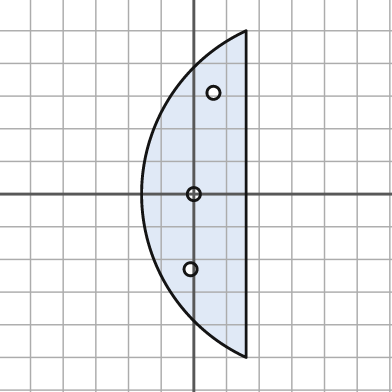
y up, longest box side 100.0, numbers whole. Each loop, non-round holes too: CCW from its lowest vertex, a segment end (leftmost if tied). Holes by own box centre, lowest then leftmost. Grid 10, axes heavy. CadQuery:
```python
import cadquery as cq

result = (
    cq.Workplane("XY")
    .moveTo(16.0, -50.0)
    .lineTo(16.0, 50.0)
    .threePointArc((-16.0, 0.0), (16.0, -50.0))
    .close()
    .moveTo(-1.0, -23.0)
    .circle(2.0)
    .moveTo(0.0, 0.0)
    .circle(2.0)
    .moveTo(6.0, 31.0)
    .circle(2.0)
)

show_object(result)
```